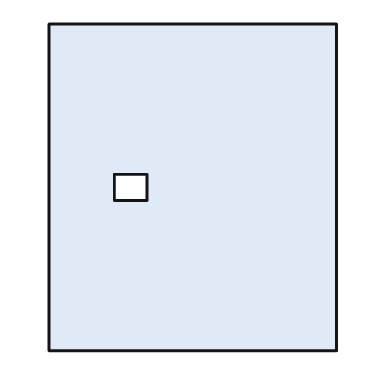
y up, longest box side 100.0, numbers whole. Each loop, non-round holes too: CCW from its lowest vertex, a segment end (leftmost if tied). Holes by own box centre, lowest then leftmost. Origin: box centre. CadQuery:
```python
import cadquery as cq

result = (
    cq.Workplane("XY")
    .moveTo(-44.0, -50.0)
    .lineTo(44.0, -50.0)
    .lineTo(44.0, 50.0)
    .lineTo(-44.0, 50.0)
    .close()
    .moveTo(-24.0, -4.0)
    .lineTo(-14.0, -4.0)
    .lineTo(-14.0, 4.0)
    .lineTo(-24.0, 4.0)
    .close()
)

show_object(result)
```